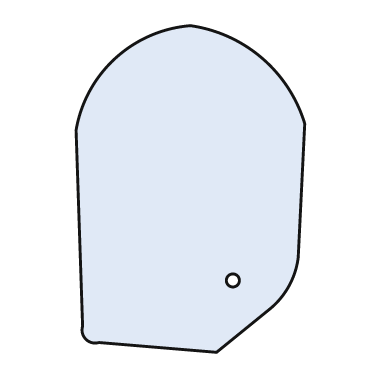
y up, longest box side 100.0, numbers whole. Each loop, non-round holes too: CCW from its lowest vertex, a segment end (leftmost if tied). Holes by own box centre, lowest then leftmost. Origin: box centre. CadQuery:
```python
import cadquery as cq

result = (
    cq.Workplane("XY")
    .moveTo(8.0, -50.0)
    .lineTo(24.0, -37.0)
    .threePointArc((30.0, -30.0), (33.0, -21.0))
    .lineTo(35.0, 20.0)
    .threePointArc((22.0, 40.0), (0.0, 50.0))
    .threePointArc((-23.0, 40.0), (-35.0, 18.0))
    .lineTo(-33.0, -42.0)
    .threePointArc((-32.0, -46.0), (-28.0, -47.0))
    .close()
    .moveTo(13.0, -28.0)
    .circle(2.0)
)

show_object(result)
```